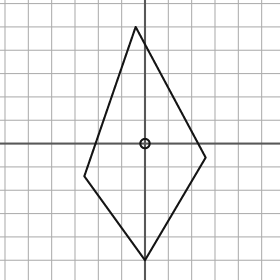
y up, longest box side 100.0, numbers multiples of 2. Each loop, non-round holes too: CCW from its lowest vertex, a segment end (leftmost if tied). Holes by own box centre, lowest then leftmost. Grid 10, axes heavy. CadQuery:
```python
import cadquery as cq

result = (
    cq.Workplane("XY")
    .moveTo(0.0, -50.0)
    .lineTo(26.0, -6.0)
    .lineTo(-4.0, 50.0)
    .lineTo(-26.0, -14.0)
    .close()
    .moveTo(0.0, 0.0)
    .circle(2.0)
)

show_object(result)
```